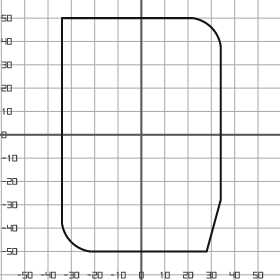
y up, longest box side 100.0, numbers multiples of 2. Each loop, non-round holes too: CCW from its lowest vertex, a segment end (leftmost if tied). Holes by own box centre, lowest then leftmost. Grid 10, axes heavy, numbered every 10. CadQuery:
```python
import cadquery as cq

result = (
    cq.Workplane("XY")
    .moveTo(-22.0, -50.0)
    .lineTo(28.0, -50.0)
    .lineTo(34.0, -28.0)
    .lineTo(34.0, 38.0)
    .threePointArc((30.0, 46.0), (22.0, 50.0))
    .lineTo(-34.0, 50.0)
    .lineTo(-34.0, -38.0)
    .threePointArc((-30.0, -46.0), (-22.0, -50.0))
    .close()
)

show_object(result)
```